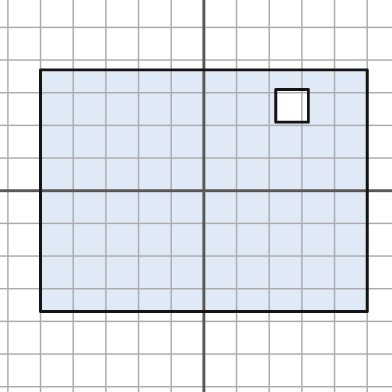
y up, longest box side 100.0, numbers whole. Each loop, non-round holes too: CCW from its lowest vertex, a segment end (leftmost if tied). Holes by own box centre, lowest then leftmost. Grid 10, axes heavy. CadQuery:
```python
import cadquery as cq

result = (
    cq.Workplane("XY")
    .moveTo(-50.0, -37.0)
    .lineTo(50.0, -37.0)
    .lineTo(50.0, 37.0)
    .lineTo(-50.0, 37.0)
    .close()
    .moveTo(22.0, 21.0)
    .lineTo(32.0, 21.0)
    .lineTo(32.0, 31.0)
    .lineTo(22.0, 31.0)
    .close()
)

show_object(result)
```